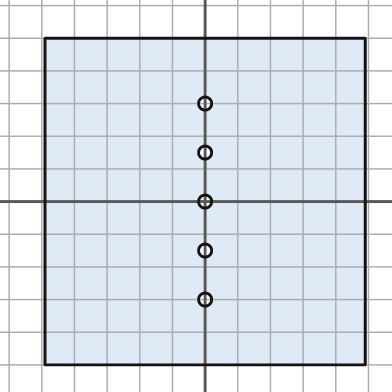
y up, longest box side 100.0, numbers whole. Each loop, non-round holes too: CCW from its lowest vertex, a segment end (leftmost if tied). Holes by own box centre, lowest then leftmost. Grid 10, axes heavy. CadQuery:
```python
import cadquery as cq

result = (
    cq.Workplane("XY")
    .moveTo(-49.0, -50.0)
    .lineTo(49.0, -50.0)
    .lineTo(49.0, 50.0)
    .lineTo(-49.0, 50.0)
    .close()
    .moveTo(0.0, -30.0)
    .circle(2.0)
    .moveTo(0.0, -15.0)
    .circle(2.0)
    .moveTo(0.0, 0.0)
    .circle(2.0)
    .moveTo(0.0, 15.0)
    .circle(2.0)
    .moveTo(0.0, 30.0)
    .circle(2.0)
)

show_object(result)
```